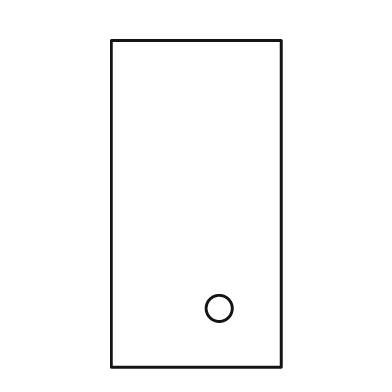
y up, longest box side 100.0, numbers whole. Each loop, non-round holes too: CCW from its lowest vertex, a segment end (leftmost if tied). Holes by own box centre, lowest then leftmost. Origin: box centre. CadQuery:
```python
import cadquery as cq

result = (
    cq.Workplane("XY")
    .moveTo(-26.0, -50.0)
    .lineTo(26.0, -50.0)
    .lineTo(26.0, 50.0)
    .lineTo(-26.0, 50.0)
    .close()
    .moveTo(7.0, -32.0)
    .circle(4.0)
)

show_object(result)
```